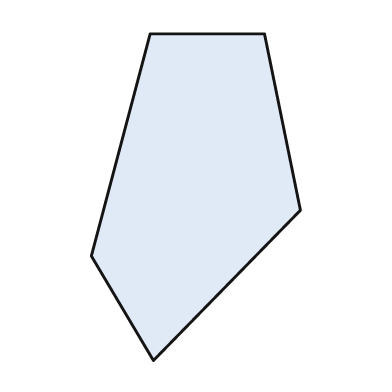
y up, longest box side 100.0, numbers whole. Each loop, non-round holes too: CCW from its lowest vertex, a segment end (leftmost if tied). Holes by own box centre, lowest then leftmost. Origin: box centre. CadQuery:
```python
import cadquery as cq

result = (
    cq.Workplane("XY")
    .moveTo(-13.0, -50.0)
    .lineTo(32.0, -4.0)
    .lineTo(21.0, 50.0)
    .lineTo(-14.0, 50.0)
    .lineTo(-32.0, -18.0)
    .close()
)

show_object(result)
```